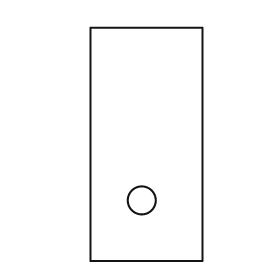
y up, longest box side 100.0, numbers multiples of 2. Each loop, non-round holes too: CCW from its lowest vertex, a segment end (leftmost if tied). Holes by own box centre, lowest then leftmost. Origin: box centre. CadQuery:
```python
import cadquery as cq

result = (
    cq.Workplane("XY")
    .moveTo(-24.0, -50.0)
    .lineTo(24.0, -50.0)
    .lineTo(24.0, 50.0)
    .lineTo(-24.0, 50.0)
    .close()
    .moveTo(-2.0, -24.0)
    .circle(6.0)
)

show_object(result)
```